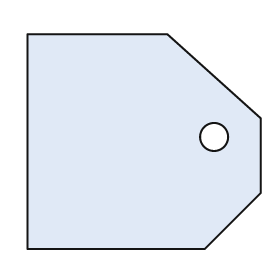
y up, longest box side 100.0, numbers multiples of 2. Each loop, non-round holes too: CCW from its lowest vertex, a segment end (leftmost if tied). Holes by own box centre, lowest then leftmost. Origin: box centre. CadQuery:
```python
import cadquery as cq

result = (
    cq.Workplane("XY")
    .moveTo(-50.0, -46.0)
    .lineTo(26.0, -46.0)
    .lineTo(50.0, -22.0)
    .lineTo(50.0, 10.0)
    .lineTo(10.0, 46.0)
    .lineTo(-50.0, 46.0)
    .close()
    .moveTo(30.0, 2.0)
    .circle(6.0)
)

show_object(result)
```